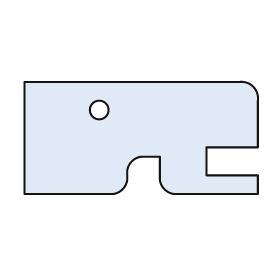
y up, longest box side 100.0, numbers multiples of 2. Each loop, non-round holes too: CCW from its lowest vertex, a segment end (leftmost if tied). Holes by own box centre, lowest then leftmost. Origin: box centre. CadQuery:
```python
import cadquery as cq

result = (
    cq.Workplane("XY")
    .moveTo(-50.0, -24.0)
    .lineTo(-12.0, -24.0)
    .threePointArc((-8.0, -22.0), (-6.0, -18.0))
    .lineTo(-6.0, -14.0)
    .threePointArc((-4.0, -10.0), (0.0, -8.0))
    .lineTo(8.0, -8.0)
    .lineTo(8.0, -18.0)
    .threePointArc((10.0, -22.0), (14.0, -24.0))
    .lineTo(50.0, -24.0)
    .lineTo(50.0, -16.0)
    .lineTo(28.0, -16.0)
    .lineTo(28.0, -4.0)
    .lineTo(50.0, -4.0)
    .lineTo(50.0, 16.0)
    .threePointArc((48.0, 22.0), (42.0, 24.0))
    .lineTo(-50.0, 24.0)
    .close()
    .moveTo(-18.0, 12.0)
    .circle(4.0)
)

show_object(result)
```